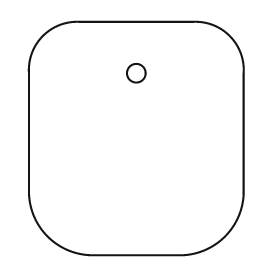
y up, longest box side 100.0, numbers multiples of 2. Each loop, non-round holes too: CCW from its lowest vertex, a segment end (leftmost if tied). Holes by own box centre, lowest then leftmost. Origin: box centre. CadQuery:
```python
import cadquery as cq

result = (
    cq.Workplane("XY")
    .moveTo(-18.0, -50.0)
    .lineTo(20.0, -50.0)
    .threePointArc((38.0, -42.0), (46.0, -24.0))
    .lineTo(46.0, 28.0)
    .threePointArc((40.0, 44.0), (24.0, 50.0))
    .lineTo(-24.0, 50.0)
    .threePointArc((-40.0, 44.0), (-46.0, 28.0))
    .lineTo(-46.0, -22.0)
    .threePointArc((-38.0, -42.0), (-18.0, -50.0))
    .close()
    .moveTo(0.0, 28.0)
    .circle(4.0)
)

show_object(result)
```